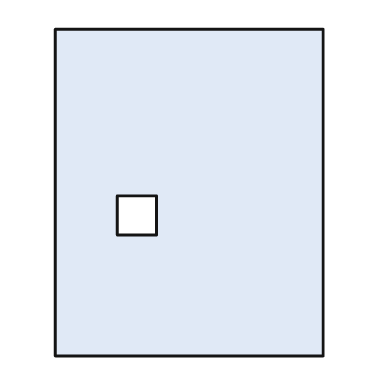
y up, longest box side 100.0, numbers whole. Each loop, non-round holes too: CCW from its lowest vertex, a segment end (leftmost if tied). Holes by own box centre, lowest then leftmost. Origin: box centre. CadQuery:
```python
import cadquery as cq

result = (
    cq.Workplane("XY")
    .moveTo(-41.0, -50.0)
    .lineTo(41.0, -50.0)
    .lineTo(41.0, 50.0)
    .lineTo(-41.0, 50.0)
    .close()
    .moveTo(-22.0, -13.0)
    .lineTo(-10.0, -13.0)
    .lineTo(-10.0, -1.0)
    .lineTo(-22.0, -1.0)
    .close()
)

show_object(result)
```